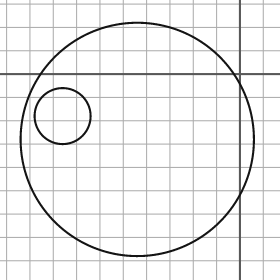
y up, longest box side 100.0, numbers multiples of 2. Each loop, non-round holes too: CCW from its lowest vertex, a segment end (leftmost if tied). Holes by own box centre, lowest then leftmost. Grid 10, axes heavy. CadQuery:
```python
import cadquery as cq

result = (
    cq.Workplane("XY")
    .moveTo(-44.0, -28.0)
    .circle(50.0)
    .moveTo(-76.0, -18.0)
    .circle(12.0)
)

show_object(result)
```